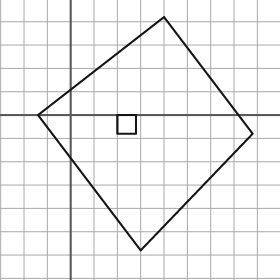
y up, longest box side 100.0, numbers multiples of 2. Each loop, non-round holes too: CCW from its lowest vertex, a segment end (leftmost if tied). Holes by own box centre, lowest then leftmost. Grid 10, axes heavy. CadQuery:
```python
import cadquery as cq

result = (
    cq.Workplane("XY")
    .moveTo(30.0, -58.0)
    .lineTo(78.0, -8.0)
    .lineTo(40.0, 42.0)
    .lineTo(-14.0, 0.0)
    .close()
    .moveTo(20.0, -8.0)
    .lineTo(28.0, -8.0)
    .lineTo(28.0, 0.0)
    .lineTo(20.0, 0.0)
    .close()
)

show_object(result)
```